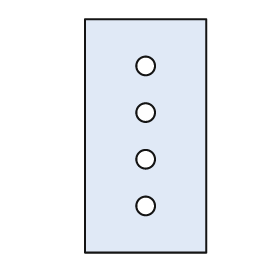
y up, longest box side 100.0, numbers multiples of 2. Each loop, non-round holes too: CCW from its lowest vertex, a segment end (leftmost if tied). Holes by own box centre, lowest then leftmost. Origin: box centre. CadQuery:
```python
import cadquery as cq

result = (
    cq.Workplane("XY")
    .moveTo(-26.0, -50.0)
    .lineTo(26.0, -50.0)
    .lineTo(26.0, 50.0)
    .lineTo(-26.0, 50.0)
    .close()
    .moveTo(0.0, -30.0)
    .circle(4.0)
    .moveTo(0.0, -10.0)
    .circle(4.0)
    .moveTo(0.0, 10.0)
    .circle(4.0)
    .moveTo(0.0, 30.0)
    .circle(4.0)
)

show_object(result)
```